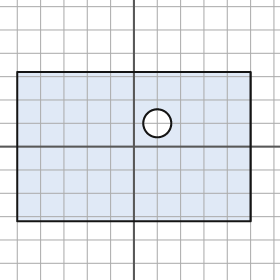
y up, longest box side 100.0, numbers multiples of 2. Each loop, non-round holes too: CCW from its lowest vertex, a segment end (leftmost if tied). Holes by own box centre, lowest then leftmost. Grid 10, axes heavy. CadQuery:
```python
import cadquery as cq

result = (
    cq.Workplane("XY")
    .moveTo(-50.0, -32.0)
    .lineTo(50.0, -32.0)
    .lineTo(50.0, 32.0)
    .lineTo(-50.0, 32.0)
    .close()
    .moveTo(10.0, 10.0)
    .circle(6.0)
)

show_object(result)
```